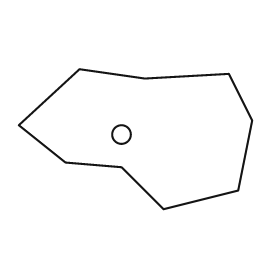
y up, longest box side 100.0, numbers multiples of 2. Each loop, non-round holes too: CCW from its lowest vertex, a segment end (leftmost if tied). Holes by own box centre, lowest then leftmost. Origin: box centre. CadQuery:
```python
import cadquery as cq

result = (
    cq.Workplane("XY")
    .moveTo(12.0, -30.0)
    .lineTo(44.0, -22.0)
    .lineTo(50.0, 8.0)
    .lineTo(40.0, 28.0)
    .lineTo(4.0, 26.0)
    .lineTo(-24.0, 30.0)
    .lineTo(-50.0, 6.0)
    .lineTo(-30.0, -10.0)
    .lineTo(-6.0, -12.0)
    .close()
    .moveTo(-6.0, 2.0)
    .circle(4.0)
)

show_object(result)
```